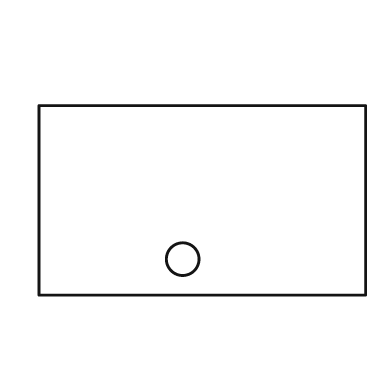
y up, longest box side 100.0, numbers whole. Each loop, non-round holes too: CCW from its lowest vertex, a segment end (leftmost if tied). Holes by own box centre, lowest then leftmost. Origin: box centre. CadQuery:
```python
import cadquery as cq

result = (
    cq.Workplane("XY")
    .moveTo(-50.0, -29.0)
    .lineTo(50.0, -29.0)
    .lineTo(50.0, 29.0)
    .lineTo(-50.0, 29.0)
    .close()
    .moveTo(-6.0, -18.0)
    .circle(5.0)
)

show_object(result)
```